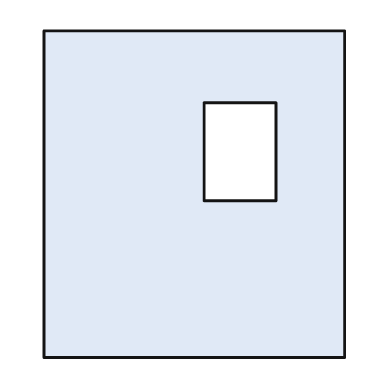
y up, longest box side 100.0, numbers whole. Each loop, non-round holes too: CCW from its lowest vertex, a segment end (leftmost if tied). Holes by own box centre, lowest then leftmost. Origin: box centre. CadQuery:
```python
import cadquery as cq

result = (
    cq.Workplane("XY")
    .moveTo(-46.0, -50.0)
    .lineTo(46.0, -50.0)
    .lineTo(46.0, 50.0)
    .lineTo(-46.0, 50.0)
    .close()
    .moveTo(3.0, -2.0)
    .lineTo(25.0, -2.0)
    .lineTo(25.0, 28.0)
    .lineTo(3.0, 28.0)
    .close()
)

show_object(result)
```